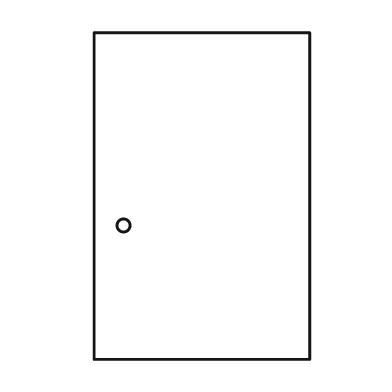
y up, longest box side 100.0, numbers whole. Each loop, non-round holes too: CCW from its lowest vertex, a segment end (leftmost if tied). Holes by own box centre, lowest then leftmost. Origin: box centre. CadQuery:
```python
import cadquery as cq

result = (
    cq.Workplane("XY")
    .moveTo(-33.0, -50.0)
    .lineTo(33.0, -50.0)
    .lineTo(33.0, 50.0)
    .lineTo(-33.0, 50.0)
    .close()
    .moveTo(-24.0, -9.0)
    .circle(2.0)
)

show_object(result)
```